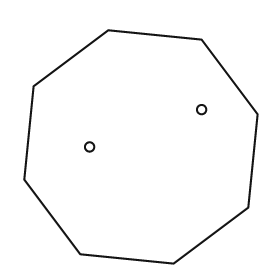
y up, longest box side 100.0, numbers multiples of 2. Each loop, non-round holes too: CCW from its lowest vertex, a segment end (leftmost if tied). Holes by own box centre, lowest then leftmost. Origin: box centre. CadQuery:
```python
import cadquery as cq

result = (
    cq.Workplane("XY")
    .moveTo(14.0, -50.0)
    .lineTo(46.0, -26.0)
    .lineTo(50.0, 14.0)
    .lineTo(26.0, 46.0)
    .lineTo(-14.0, 50.0)
    .lineTo(-46.0, 26.0)
    .lineTo(-50.0, -14.0)
    .lineTo(-26.0, -46.0)
    .close()
    .moveTo(-22.0, 0.0)
    .circle(2.0)
    .moveTo(26.0, 16.0)
    .circle(2.0)
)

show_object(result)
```